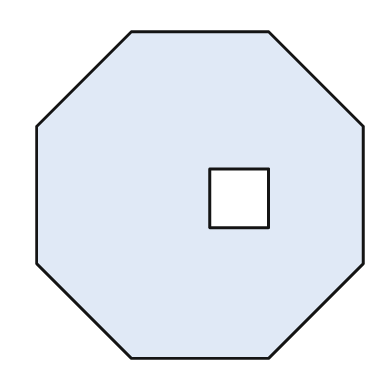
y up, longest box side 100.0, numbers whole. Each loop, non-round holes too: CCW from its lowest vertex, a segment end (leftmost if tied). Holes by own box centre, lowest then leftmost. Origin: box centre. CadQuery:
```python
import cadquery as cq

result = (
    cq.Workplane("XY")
    .moveTo(-21.0, -50.0)
    .lineTo(21.0, -50.0)
    .lineTo(50.0, -21.0)
    .lineTo(50.0, 21.0)
    .lineTo(21.0, 50.0)
    .lineTo(-21.0, 50.0)
    .lineTo(-50.0, 21.0)
    .lineTo(-50.0, -21.0)
    .close()
    .moveTo(3.0, -10.0)
    .lineTo(21.0, -10.0)
    .lineTo(21.0, 8.0)
    .lineTo(3.0, 8.0)
    .close()
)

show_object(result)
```